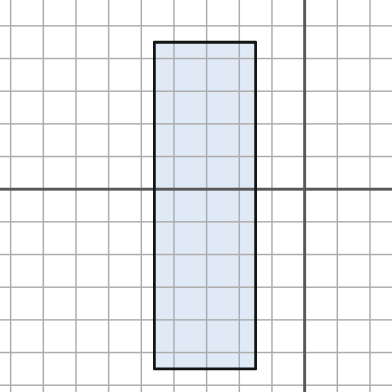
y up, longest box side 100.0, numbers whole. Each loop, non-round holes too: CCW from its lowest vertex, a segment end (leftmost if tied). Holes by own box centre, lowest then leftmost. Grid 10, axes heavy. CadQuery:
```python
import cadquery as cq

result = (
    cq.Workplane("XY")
    .moveTo(-46.0, -55.0)
    .lineTo(-15.0, -55.0)
    .lineTo(-15.0, 45.0)
    .lineTo(-46.0, 45.0)
    .close()
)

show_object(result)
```